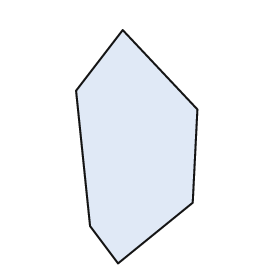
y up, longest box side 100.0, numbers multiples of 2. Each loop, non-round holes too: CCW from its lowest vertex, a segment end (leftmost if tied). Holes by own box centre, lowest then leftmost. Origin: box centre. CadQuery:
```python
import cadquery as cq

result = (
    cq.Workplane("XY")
    .moveTo(-8.0, -50.0)
    .lineTo(24.0, -24.0)
    .lineTo(26.0, 16.0)
    .lineTo(-6.0, 50.0)
    .lineTo(-26.0, 24.0)
    .lineTo(-20.0, -34.0)
    .close()
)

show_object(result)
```